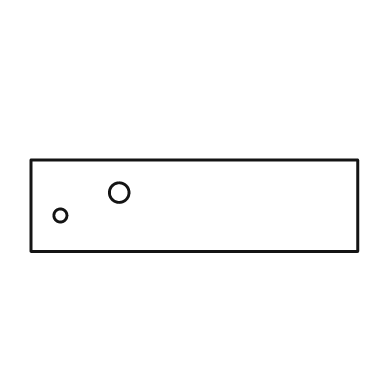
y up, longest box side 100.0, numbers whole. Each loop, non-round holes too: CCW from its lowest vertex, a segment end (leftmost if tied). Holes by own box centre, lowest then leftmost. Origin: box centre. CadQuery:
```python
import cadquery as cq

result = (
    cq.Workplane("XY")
    .moveTo(-50.0, -14.0)
    .lineTo(50.0, -14.0)
    .lineTo(50.0, 14.0)
    .lineTo(-50.0, 14.0)
    .close()
    .moveTo(-41.0, -3.0)
    .circle(2.0)
    .moveTo(-23.0, 4.0)
    .circle(3.0)
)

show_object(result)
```